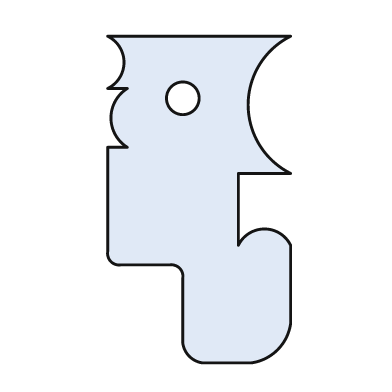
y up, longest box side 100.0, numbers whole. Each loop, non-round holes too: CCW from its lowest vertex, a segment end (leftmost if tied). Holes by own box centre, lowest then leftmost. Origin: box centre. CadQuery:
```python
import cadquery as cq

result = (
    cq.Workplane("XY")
    .moveTo(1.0, -50.0)
    .lineTo(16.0, -50.0)
    .threePointArc((24.0, -46.0), (28.0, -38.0))
    .lineTo(28.0, -14.0)
    .threePointArc((20.0, -9.0), (12.0, -14.0))
    .lineTo(12.0, 8.0)
    .lineTo(28.0, 8.0)
    .threePointArc((15.0, 29.0), (28.0, 50.0))
    .lineTo(-28.0, 50.0)
    .threePointArc((-23.0, 42.0), (-28.0, 34.0))
    .lineTo(-22.0, 34.0)
    .threePointArc((-27.0, 25.0), (-22.0, 16.0))
    .lineTo(-28.0, 16.0)
    .lineTo(-28.0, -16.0)
    .threePointArc((-27.0, -19.0), (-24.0, -20.0))
    .lineTo(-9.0, -20.0)
    .threePointArc((-6.0, -21.0), (-5.0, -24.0))
    .lineTo(-5.0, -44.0)
    .threePointArc((-3.0, -48.0), (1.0, -50.0))
    .close()
    .moveTo(-5.0, 31.0)
    .circle(5.0)
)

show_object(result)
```